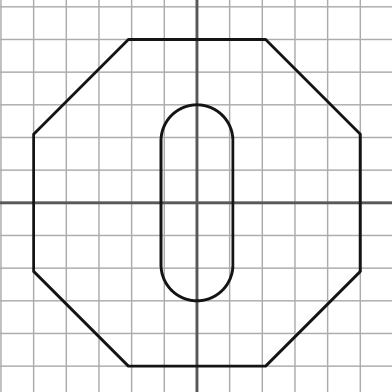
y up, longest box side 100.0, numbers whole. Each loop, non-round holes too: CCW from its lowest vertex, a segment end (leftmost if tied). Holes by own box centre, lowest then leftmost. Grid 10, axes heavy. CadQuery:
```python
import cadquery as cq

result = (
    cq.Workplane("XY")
    .moveTo(-21.0, -50.0)
    .lineTo(21.0, -50.0)
    .lineTo(50.0, -21.0)
    .lineTo(50.0, 21.0)
    .lineTo(21.0, 50.0)
    .lineTo(-21.0, 50.0)
    .lineTo(-50.0, 21.0)
    .lineTo(-50.0, -21.0)
    .close()
    .moveTo(-11.0, -19.0)
    .threePointArc((0.0, -30.0), (11.0, -19.0))
    .lineTo(11.0, 19.0)
    .threePointArc((0.0, 30.0), (-11.0, 19.0))
    .close()
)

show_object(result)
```